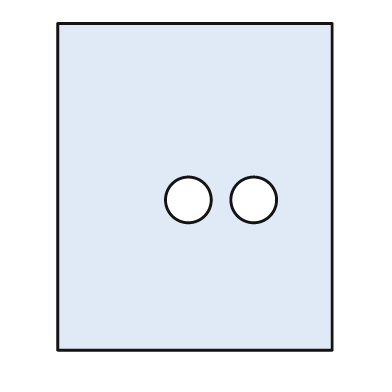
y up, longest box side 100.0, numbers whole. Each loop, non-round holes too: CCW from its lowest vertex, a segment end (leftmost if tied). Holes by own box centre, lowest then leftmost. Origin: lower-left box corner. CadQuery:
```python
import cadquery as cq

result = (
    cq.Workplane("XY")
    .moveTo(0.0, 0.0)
    .lineTo(84.0, 0.0)
    .lineTo(84.0, 100.0)
    .lineTo(0.0, 100.0)
    .close()
    .moveTo(40.0, 46.0)
    .circle(7.0)
    .moveTo(60.0, 46.0)
    .circle(7.0)
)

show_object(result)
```